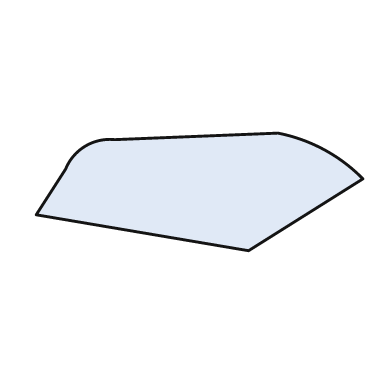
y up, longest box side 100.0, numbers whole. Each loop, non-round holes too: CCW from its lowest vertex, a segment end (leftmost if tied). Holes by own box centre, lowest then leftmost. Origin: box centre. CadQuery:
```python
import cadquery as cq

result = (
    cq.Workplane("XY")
    .moveTo(15.0, -18.0)
    .lineTo(50.0, 4.0)
    .threePointArc((38.0, 13.0), (24.0, 18.0))
    .lineTo(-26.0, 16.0)
    .threePointArc((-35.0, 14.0), (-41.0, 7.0))
    .lineTo(-50.0, -7.0)
    .close()
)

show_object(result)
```